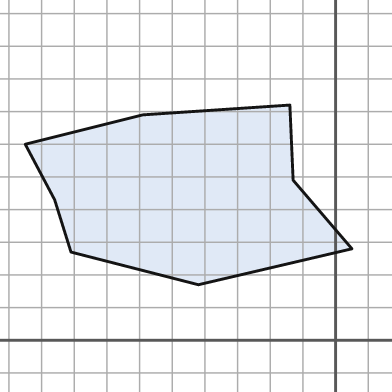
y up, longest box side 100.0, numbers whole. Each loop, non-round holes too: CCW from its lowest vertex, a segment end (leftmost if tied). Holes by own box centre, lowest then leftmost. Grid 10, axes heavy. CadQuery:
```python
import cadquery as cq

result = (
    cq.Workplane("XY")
    .moveTo(-42.0, 17.0)
    .lineTo(5.0, 28.0)
    .lineTo(-13.0, 49.0)
    .lineTo(-14.0, 72.0)
    .lineTo(-59.0, 69.0)
    .lineTo(-95.0, 60.0)
    .lineTo(-86.0, 43.0)
    .lineTo(-81.0, 27.0)
    .close()
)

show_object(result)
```